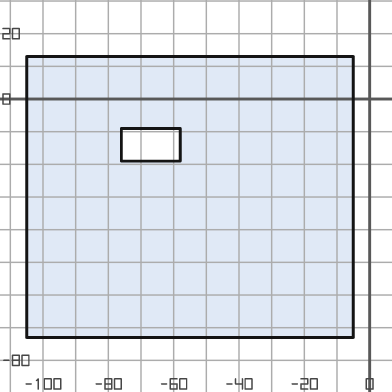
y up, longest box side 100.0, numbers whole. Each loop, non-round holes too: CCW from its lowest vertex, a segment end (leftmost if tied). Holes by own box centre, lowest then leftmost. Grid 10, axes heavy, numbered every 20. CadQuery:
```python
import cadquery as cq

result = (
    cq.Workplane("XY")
    .moveTo(-105.0, -73.0)
    .lineTo(-5.0, -73.0)
    .lineTo(-5.0, 13.0)
    .lineTo(-105.0, 13.0)
    .close()
    .moveTo(-76.0, -19.0)
    .lineTo(-58.0, -19.0)
    .lineTo(-58.0, -9.0)
    .lineTo(-76.0, -9.0)
    .close()
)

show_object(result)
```